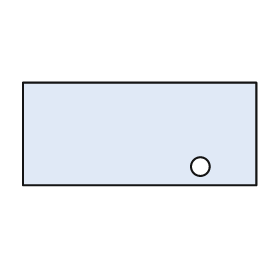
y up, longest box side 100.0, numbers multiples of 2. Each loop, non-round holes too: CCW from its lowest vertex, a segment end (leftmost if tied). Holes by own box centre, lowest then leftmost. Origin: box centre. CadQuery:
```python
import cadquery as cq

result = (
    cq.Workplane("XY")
    .moveTo(-50.0, -22.0)
    .lineTo(50.0, -22.0)
    .lineTo(50.0, 22.0)
    .lineTo(-50.0, 22.0)
    .close()
    .moveTo(26.0, -14.0)
    .circle(4.0)
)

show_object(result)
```